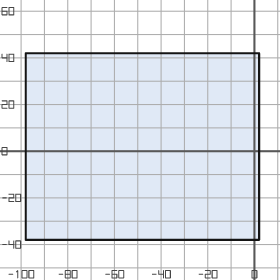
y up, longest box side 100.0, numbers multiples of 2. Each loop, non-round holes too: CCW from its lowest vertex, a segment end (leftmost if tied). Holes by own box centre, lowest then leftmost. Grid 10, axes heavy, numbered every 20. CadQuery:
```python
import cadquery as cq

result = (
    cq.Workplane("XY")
    .moveTo(-98.0, -38.0)
    .lineTo(2.0, -38.0)
    .lineTo(2.0, 42.0)
    .lineTo(-98.0, 42.0)
    .close()
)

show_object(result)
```